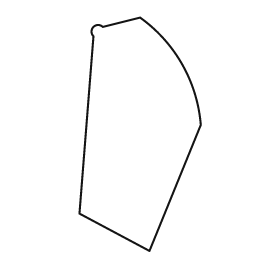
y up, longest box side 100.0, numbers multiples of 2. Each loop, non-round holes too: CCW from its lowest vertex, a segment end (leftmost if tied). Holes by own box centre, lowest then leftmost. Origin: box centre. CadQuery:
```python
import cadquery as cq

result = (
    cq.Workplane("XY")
    .moveTo(4.0, -50.0)
    .lineTo(26.0, 4.0)
    .threePointArc((18.0, 30.0), (0.0, 50.0))
    .lineTo(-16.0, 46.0)
    .threePointArc((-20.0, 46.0), (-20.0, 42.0))
    .lineTo(-26.0, -34.0)
    .close()
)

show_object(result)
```